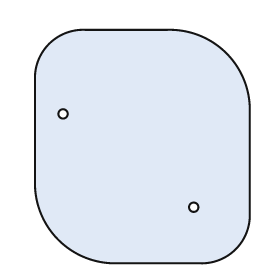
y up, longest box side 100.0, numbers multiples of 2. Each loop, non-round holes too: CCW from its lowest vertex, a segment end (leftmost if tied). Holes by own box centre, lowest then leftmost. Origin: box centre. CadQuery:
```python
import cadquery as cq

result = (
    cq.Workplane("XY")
    .moveTo(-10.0, -50.0)
    .lineTo(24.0, -50.0)
    .threePointArc((40.0, -44.0), (46.0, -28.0))
    .lineTo(46.0, 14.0)
    .threePointArc((36.0, 40.0), (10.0, 50.0))
    .lineTo(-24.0, 50.0)
    .threePointArc((-40.0, 44.0), (-46.0, 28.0))
    .lineTo(-46.0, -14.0)
    .threePointArc((-36.0, -40.0), (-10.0, -50.0))
    .close()
    .moveTo(22.0, -26.0)
    .circle(2.0)
    .moveTo(-34.0, 14.0)
    .circle(2.0)
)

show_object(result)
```